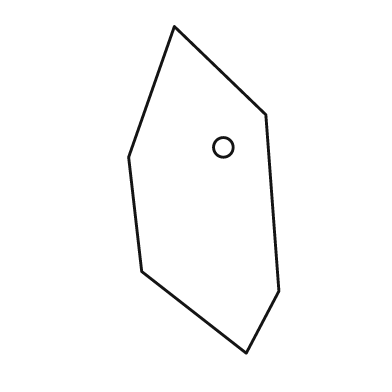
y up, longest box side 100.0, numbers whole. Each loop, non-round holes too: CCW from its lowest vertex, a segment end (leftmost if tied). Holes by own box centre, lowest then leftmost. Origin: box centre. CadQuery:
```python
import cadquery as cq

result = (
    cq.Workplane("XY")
    .moveTo(13.0, -50.0)
    .lineTo(23.0, -31.0)
    .lineTo(19.0, 23.0)
    .lineTo(-9.0, 50.0)
    .lineTo(-23.0, 10.0)
    .lineTo(-19.0, -25.0)
    .close()
    .moveTo(6.0, 13.0)
    .circle(3.0)
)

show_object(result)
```